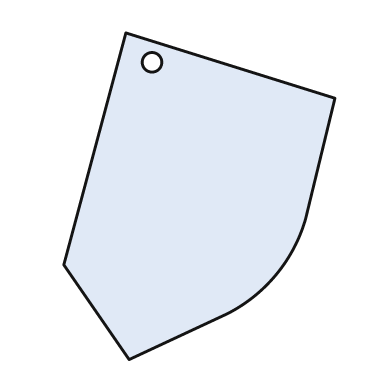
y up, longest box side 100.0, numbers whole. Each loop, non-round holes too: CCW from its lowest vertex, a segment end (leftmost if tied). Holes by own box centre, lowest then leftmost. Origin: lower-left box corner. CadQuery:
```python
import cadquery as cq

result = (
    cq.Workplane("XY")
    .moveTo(20.0, 0.0)
    .lineTo(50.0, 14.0)
    .threePointArc((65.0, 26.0), (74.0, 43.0))
    .lineTo(83.0, 80.0)
    .lineTo(19.0, 100.0)
    .lineTo(0.0, 29.0)
    .close()
    .moveTo(27.0, 91.0)
    .circle(3.0)
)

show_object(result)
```